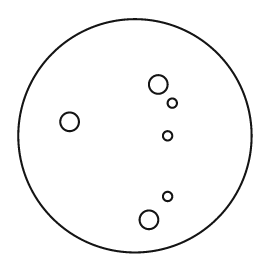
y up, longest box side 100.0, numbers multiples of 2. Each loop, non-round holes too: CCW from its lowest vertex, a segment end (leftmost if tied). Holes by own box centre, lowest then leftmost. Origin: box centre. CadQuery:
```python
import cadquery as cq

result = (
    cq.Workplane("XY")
    .moveTo(0.0, 0.0)
    .circle(50.0)
    .moveTo(6.0, -36.0)
    .circle(4.0)
    .moveTo(14.0, -26.0)
    .circle(2.0)
    .moveTo(14.0, 0.0)
    .circle(2.0)
    .moveTo(-28.0, 6.0)
    .circle(4.0)
    .moveTo(16.0, 14.0)
    .circle(2.0)
    .moveTo(10.0, 22.0)
    .circle(4.0)
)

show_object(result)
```